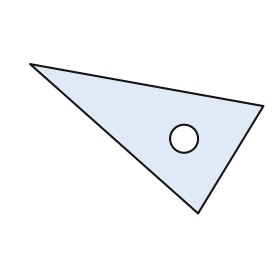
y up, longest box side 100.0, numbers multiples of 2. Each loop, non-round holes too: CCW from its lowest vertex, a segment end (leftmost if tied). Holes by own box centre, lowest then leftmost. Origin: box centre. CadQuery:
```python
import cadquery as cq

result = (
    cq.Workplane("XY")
    .moveTo(22.0, -32.0)
    .lineTo(50.0, 14.0)
    .lineTo(-50.0, 32.0)
    .close()
    .moveTo(16.0, 0.0)
    .circle(6.0)
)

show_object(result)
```